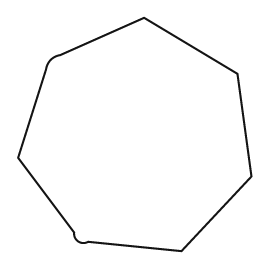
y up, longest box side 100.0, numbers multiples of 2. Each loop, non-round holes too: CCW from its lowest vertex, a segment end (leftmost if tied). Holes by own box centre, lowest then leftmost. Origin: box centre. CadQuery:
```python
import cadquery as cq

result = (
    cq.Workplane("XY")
    .moveTo(20.0, -50.0)
    .lineTo(50.0, -18.0)
    .lineTo(44.0, 26.0)
    .lineTo(4.0, 50.0)
    .lineTo(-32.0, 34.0)
    .threePointArc((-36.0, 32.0), (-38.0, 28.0))
    .lineTo(-50.0, -10.0)
    .lineTo(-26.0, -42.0)
    .threePointArc((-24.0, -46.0), (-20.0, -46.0))
    .close()
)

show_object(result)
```